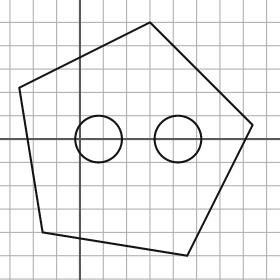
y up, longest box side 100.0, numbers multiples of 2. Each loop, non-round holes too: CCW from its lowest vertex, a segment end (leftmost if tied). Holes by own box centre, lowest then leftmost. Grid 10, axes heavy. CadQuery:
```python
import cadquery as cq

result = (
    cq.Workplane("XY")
    .moveTo(46.0, -50.0)
    .lineTo(74.0, 6.0)
    .lineTo(30.0, 50.0)
    .lineTo(-26.0, 22.0)
    .lineTo(-16.0, -40.0)
    .close()
    .moveTo(8.0, 0.0)
    .circle(10.0)
    .moveTo(42.0, 0.0)
    .circle(10.0)
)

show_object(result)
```